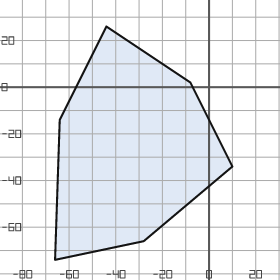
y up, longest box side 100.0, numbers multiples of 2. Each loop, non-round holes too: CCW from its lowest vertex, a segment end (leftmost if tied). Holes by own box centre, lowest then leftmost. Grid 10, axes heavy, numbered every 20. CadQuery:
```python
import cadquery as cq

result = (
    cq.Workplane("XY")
    .moveTo(-66.0, -74.0)
    .lineTo(-28.0, -66.0)
    .lineTo(10.0, -34.0)
    .lineTo(-8.0, 2.0)
    .lineTo(-44.0, 26.0)
    .lineTo(-64.0, -14.0)
    .close()
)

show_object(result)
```